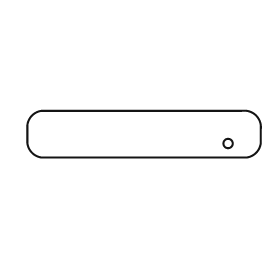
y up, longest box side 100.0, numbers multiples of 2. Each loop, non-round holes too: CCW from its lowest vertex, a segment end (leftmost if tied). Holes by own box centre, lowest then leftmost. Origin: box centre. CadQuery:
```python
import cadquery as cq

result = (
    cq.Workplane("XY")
    .moveTo(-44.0, -10.0)
    .lineTo(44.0, -10.0)
    .threePointArc((48.0, -8.0), (50.0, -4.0))
    .lineTo(50.0, 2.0)
    .threePointArc((48.0, 8.0), (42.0, 10.0))
    .lineTo(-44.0, 10.0)
    .threePointArc((-48.0, 8.0), (-50.0, 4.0))
    .lineTo(-50.0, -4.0)
    .threePointArc((-48.0, -8.0), (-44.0, -10.0))
    .close()
    .moveTo(36.0, -4.0)
    .circle(2.0)
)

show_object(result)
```